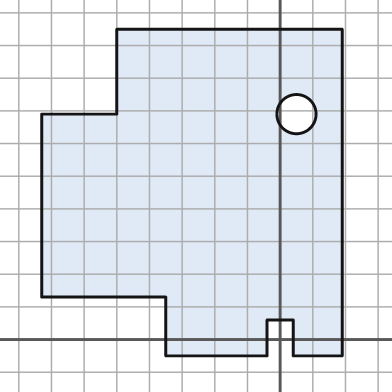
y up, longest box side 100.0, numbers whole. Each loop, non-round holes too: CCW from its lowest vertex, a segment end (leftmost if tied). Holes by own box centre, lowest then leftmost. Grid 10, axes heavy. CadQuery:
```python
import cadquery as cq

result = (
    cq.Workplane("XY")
    .moveTo(-35.0, -5.0)
    .lineTo(-4.0, -5.0)
    .lineTo(-4.0, 6.0)
    .lineTo(4.0, 6.0)
    .lineTo(4.0, -5.0)
    .lineTo(19.0, -5.0)
    .lineTo(19.0, 95.0)
    .lineTo(-50.0, 95.0)
    .lineTo(-50.0, 69.0)
    .lineTo(-73.0, 69.0)
    .lineTo(-73.0, 13.0)
    .lineTo(-35.0, 13.0)
    .close()
    .moveTo(5.0, 69.0)
    .circle(6.0)
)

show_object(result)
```